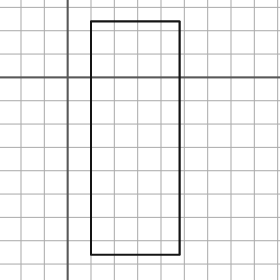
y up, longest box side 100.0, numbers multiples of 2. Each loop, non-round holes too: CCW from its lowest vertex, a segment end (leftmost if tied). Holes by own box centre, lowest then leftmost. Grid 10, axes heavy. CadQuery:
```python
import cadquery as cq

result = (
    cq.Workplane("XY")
    .moveTo(10.0, -76.0)
    .lineTo(48.0, -76.0)
    .lineTo(48.0, 24.0)
    .lineTo(10.0, 24.0)
    .close()
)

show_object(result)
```